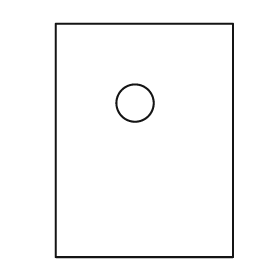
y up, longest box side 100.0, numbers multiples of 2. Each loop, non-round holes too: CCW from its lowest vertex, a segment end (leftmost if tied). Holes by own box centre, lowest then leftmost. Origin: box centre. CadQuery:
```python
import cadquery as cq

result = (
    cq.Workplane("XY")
    .moveTo(-38.0, -50.0)
    .lineTo(38.0, -50.0)
    .lineTo(38.0, 50.0)
    .lineTo(-38.0, 50.0)
    .close()
    .moveTo(-4.0, 16.0)
    .circle(8.0)
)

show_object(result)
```